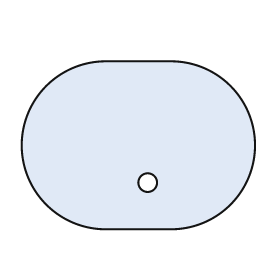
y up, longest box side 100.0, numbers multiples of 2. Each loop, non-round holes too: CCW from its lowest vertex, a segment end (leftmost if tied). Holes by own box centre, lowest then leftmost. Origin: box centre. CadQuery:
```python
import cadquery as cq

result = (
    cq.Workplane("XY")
    .moveTo(-14.0, -36.0)
    .lineTo(14.0, -36.0)
    .threePointArc((50.0, 0.0), (14.0, 36.0))
    .lineTo(-14.0, 36.0)
    .threePointArc((-50.0, 0.0), (-14.0, -36.0))
    .close()
    .moveTo(4.0, -16.0)
    .circle(4.0)
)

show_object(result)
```